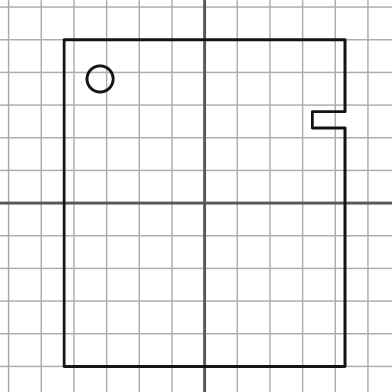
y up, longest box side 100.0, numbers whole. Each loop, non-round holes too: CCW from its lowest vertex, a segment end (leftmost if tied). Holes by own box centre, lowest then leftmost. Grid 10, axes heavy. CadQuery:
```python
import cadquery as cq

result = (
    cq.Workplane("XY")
    .moveTo(-43.0, -50.0)
    .lineTo(43.0, -50.0)
    .lineTo(43.0, 23.0)
    .lineTo(33.0, 23.0)
    .lineTo(33.0, 28.0)
    .lineTo(43.0, 28.0)
    .lineTo(43.0, 50.0)
    .lineTo(-43.0, 50.0)
    .close()
    .moveTo(-32.0, 38.0)
    .circle(4.0)
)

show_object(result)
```